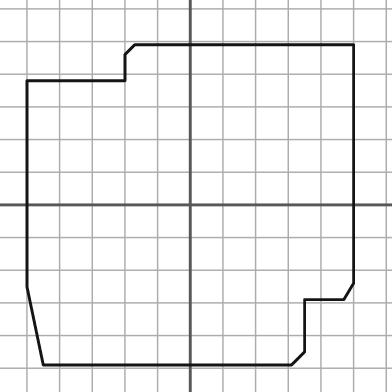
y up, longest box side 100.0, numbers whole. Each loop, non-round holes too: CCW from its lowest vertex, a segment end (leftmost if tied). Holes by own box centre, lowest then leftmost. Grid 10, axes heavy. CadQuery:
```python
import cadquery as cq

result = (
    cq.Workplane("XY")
    .moveTo(-45.0, -49.0)
    .lineTo(31.0, -49.0)
    .lineTo(35.0, -45.0)
    .lineTo(35.0, -29.0)
    .lineTo(47.0, -29.0)
    .lineTo(50.0, -24.0)
    .lineTo(50.0, 49.0)
    .lineTo(-17.0, 49.0)
    .lineTo(-20.0, 46.0)
    .lineTo(-20.0, 38.0)
    .lineTo(-50.0, 38.0)
    .lineTo(-50.0, -25.0)
    .close()
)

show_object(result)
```